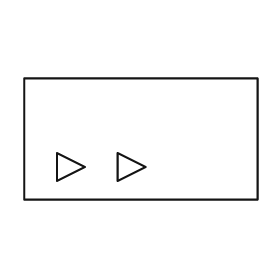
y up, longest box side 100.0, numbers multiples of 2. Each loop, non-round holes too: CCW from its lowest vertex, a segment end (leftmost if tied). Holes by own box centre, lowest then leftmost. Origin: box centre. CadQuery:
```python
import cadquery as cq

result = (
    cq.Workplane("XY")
    .moveTo(-50.0, -26.0)
    .lineTo(50.0, -26.0)
    .lineTo(50.0, 26.0)
    .lineTo(-50.0, 26.0)
    .close()
    .moveTo(-36.0, -18.0)
    .lineTo(-24.0, -12.0)
    .lineTo(-36.0, -6.0)
    .close()
    .moveTo(-10.0, -18.0)
    .lineTo(2.0, -12.0)
    .lineTo(-10.0, -6.0)
    .close()
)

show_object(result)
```